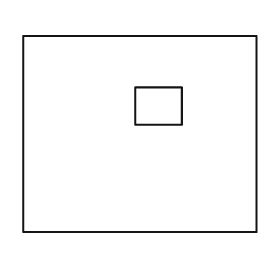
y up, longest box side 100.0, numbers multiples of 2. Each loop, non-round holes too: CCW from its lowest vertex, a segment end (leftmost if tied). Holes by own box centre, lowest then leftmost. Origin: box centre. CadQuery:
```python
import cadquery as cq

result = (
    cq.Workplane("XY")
    .moveTo(-50.0, -42.0)
    .lineTo(50.0, -42.0)
    .lineTo(50.0, 42.0)
    .lineTo(-50.0, 42.0)
    .close()
    .moveTo(-2.0, 4.0)
    .lineTo(18.0, 4.0)
    .lineTo(18.0, 20.0)
    .lineTo(-2.0, 20.0)
    .close()
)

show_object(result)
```